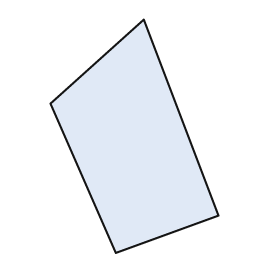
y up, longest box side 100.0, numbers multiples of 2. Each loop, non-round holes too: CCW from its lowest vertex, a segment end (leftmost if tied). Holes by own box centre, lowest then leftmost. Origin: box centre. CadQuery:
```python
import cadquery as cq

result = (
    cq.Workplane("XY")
    .moveTo(-8.0, -50.0)
    .lineTo(36.0, -34.0)
    .lineTo(4.0, 50.0)
    .lineTo(-36.0, 14.0)
    .close()
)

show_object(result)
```